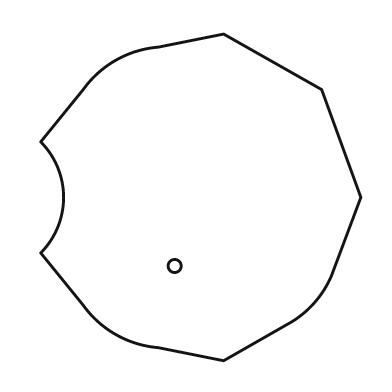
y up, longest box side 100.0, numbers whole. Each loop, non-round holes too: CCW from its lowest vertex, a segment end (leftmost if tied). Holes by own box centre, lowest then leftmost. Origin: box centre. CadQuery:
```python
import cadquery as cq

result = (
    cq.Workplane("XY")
    .moveTo(7.0, -50.0)
    .lineTo(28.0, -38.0)
    .threePointArc((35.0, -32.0), (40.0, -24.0))
    .lineTo(49.0, 0.0)
    .lineTo(37.0, 33.0)
    .lineTo(7.0, 50.0)
    .lineTo(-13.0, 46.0)
    .threePointArc((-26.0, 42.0), (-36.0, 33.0))
    .lineTo(-49.0, 17.0)
    .threePointArc((-42.0, 0.0), (-49.0, -17.0))
    .lineTo(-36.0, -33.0)
    .threePointArc((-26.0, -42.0), (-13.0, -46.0))
    .close()
    .moveTo(-8.0, -21.0)
    .circle(2.0)
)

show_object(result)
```